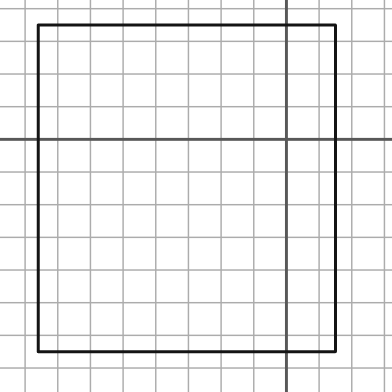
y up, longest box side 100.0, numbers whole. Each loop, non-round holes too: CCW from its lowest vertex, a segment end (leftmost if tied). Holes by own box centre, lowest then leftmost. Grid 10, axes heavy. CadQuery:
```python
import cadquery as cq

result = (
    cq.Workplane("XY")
    .moveTo(-76.0, -65.0)
    .lineTo(15.0, -65.0)
    .lineTo(15.0, 35.0)
    .lineTo(-76.0, 35.0)
    .close()
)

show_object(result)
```